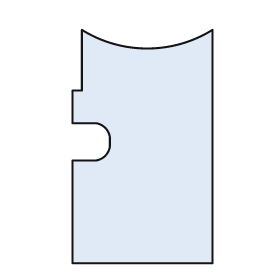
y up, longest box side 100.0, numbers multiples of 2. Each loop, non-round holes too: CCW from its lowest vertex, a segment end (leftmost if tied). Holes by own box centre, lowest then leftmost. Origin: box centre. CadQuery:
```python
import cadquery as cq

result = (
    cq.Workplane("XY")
    .moveTo(-30.0, -50.0)
    .lineTo(30.0, -50.0)
    .lineTo(30.0, 50.0)
    .threePointArc((2.0, 42.0), (-26.0, 50.0))
    .lineTo(-26.0, 24.0)
    .lineTo(-30.0, 24.0)
    .lineTo(-30.0, 10.0)
    .lineTo(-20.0, 10.0)
    .threePointArc((-16.0, 8.0), (-14.0, 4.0))
    .lineTo(-14.0, 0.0)
    .threePointArc((-16.0, -4.0), (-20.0, -6.0))
    .lineTo(-30.0, -6.0)
    .close()
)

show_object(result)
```